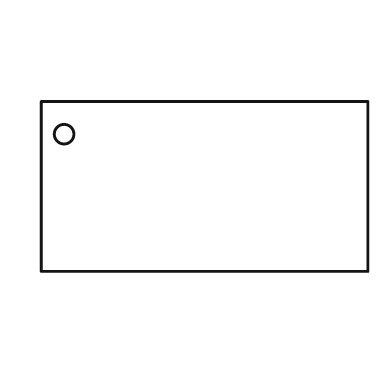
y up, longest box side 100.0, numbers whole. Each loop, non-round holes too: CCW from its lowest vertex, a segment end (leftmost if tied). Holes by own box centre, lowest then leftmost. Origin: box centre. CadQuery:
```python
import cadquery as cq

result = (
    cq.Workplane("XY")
    .moveTo(-50.0, -26.0)
    .lineTo(50.0, -26.0)
    .lineTo(50.0, 26.0)
    .lineTo(-50.0, 26.0)
    .close()
    .moveTo(-43.0, 16.0)
    .circle(3.0)
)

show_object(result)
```